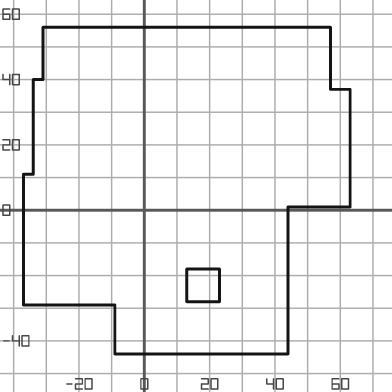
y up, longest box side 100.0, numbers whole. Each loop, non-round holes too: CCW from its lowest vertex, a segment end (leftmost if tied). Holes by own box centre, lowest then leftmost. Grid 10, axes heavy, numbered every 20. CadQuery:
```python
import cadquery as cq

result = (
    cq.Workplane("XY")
    .moveTo(-9.0, -44.0)
    .lineTo(44.0, -44.0)
    .lineTo(44.0, 1.0)
    .lineTo(63.0, 1.0)
    .lineTo(63.0, 37.0)
    .lineTo(57.0, 37.0)
    .lineTo(57.0, 56.0)
    .lineTo(-31.0, 56.0)
    .lineTo(-31.0, 40.0)
    .lineTo(-34.0, 40.0)
    .lineTo(-34.0, 11.0)
    .lineTo(-37.0, 11.0)
    .lineTo(-37.0, -29.0)
    .lineTo(-9.0, -29.0)
    .close()
    .moveTo(13.0, -28.0)
    .lineTo(23.0, -28.0)
    .lineTo(23.0, -18.0)
    .lineTo(13.0, -18.0)
    .close()
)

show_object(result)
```